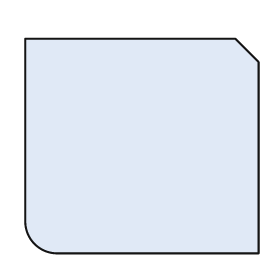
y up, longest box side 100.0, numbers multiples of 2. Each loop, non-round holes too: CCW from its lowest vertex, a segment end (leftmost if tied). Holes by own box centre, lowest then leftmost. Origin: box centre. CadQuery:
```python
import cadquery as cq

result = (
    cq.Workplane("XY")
    .moveTo(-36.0, -46.0)
    .lineTo(50.0, -46.0)
    .lineTo(50.0, 36.0)
    .lineTo(40.0, 46.0)
    .lineTo(-50.0, 46.0)
    .lineTo(-50.0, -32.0)
    .threePointArc((-46.0, -42.0), (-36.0, -46.0))
    .close()
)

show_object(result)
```